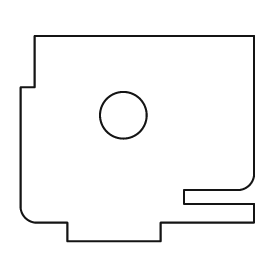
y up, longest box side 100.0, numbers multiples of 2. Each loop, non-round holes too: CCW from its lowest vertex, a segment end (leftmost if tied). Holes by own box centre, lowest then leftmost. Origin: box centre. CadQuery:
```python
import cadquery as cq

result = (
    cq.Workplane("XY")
    .moveTo(-30.0, -44.0)
    .lineTo(10.0, -44.0)
    .lineTo(10.0, -36.0)
    .lineTo(50.0, -36.0)
    .lineTo(50.0, -28.0)
    .lineTo(20.0, -28.0)
    .lineTo(20.0, -22.0)
    .lineTo(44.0, -22.0)
    .threePointArc((48.0, -20.0), (50.0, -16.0))
    .lineTo(50.0, 44.0)
    .lineTo(-44.0, 44.0)
    .lineTo(-44.0, 22.0)
    .lineTo(-50.0, 22.0)
    .lineTo(-50.0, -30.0)
    .threePointArc((-48.0, -34.0), (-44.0, -36.0))
    .lineTo(-30.0, -36.0)
    .close()
    .moveTo(-6.0, 10.0)
    .circle(10.0)
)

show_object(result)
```